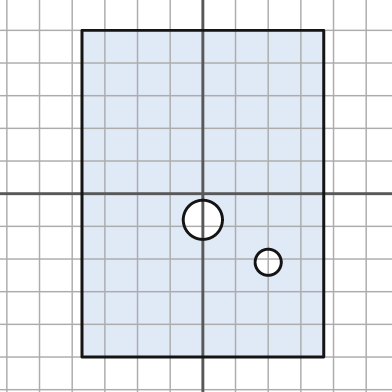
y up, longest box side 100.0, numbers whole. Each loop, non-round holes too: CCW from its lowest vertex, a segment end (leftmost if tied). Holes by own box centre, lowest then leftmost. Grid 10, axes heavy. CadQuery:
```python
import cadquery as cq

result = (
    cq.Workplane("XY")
    .moveTo(-37.0, -50.0)
    .lineTo(37.0, -50.0)
    .lineTo(37.0, 50.0)
    .lineTo(-37.0, 50.0)
    .close()
    .moveTo(20.0, -21.0)
    .circle(4.0)
    .moveTo(0.0, -8.0)
    .circle(6.0)
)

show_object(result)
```